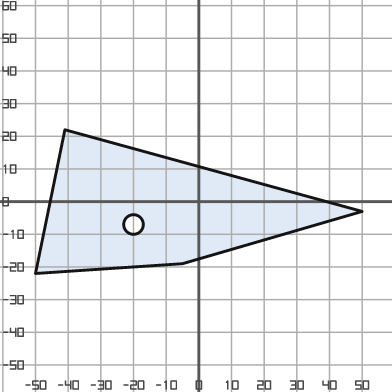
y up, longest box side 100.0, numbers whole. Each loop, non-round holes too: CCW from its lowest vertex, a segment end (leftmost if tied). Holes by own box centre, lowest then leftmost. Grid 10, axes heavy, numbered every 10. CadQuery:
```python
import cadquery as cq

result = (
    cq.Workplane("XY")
    .moveTo(-50.0, -22.0)
    .lineTo(-5.0, -19.0)
    .lineTo(50.0, -3.0)
    .lineTo(-41.0, 22.0)
    .close()
    .moveTo(-20.0, -7.0)
    .circle(3.0)
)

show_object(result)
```